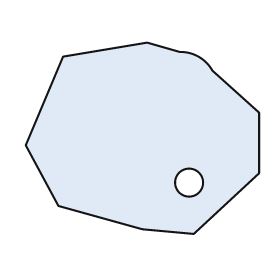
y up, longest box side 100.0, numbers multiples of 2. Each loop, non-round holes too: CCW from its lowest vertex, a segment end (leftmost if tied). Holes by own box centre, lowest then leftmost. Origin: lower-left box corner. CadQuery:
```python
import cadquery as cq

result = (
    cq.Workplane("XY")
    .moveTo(72.0, 0.0)
    .lineTo(100.0, 26.0)
    .lineTo(100.0, 52.0)
    .lineTo(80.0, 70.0)
    .threePointArc((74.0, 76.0), (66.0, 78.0))
    .lineTo(52.0, 82.0)
    .lineTo(16.0, 76.0)
    .lineTo(0.0, 38.0)
    .lineTo(14.0, 12.0)
    .lineTo(50.0, 2.0)
    .close()
    .moveTo(70.0, 22.0)
    .circle(6.0)
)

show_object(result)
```